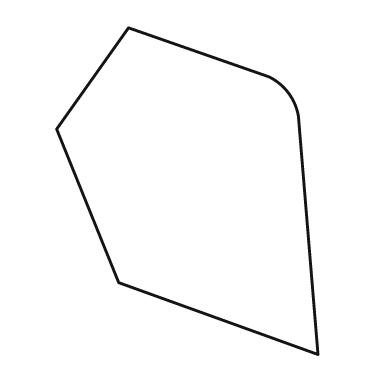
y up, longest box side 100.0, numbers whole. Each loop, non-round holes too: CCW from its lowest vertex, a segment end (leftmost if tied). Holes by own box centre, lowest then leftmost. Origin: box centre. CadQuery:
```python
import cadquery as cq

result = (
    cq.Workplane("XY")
    .moveTo(40.0, -50.0)
    .lineTo(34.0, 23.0)
    .threePointArc((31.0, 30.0), (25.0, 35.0))
    .lineTo(-18.0, 50.0)
    .lineTo(-40.0, 19.0)
    .lineTo(-21.0, -28.0)
    .close()
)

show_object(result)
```